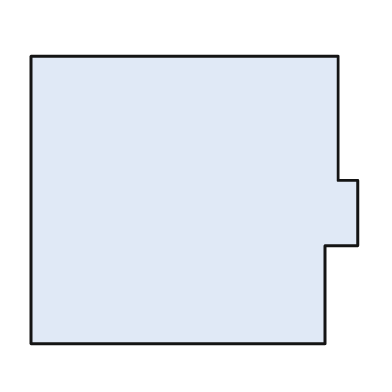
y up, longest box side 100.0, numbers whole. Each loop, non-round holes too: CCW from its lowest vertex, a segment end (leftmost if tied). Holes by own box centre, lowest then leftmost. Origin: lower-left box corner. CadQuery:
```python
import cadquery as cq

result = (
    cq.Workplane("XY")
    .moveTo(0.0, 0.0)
    .lineTo(90.0, 0.0)
    .lineTo(90.0, 30.0)
    .lineTo(100.0, 30.0)
    .lineTo(100.0, 50.0)
    .lineTo(94.0, 50.0)
    .lineTo(94.0, 88.0)
    .lineTo(0.0, 88.0)
    .close()
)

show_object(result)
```